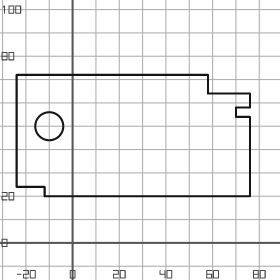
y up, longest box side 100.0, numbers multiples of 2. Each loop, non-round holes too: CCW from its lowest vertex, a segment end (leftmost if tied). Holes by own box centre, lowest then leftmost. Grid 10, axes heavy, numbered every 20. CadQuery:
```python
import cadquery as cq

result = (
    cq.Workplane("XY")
    .moveTo(-12.0, 20.0)
    .lineTo(76.0, 20.0)
    .lineTo(76.0, 54.0)
    .lineTo(70.0, 54.0)
    .lineTo(70.0, 58.0)
    .lineTo(76.0, 58.0)
    .lineTo(76.0, 64.0)
    .lineTo(58.0, 64.0)
    .lineTo(58.0, 72.0)
    .lineTo(-24.0, 72.0)
    .lineTo(-24.0, 24.0)
    .lineTo(-12.0, 24.0)
    .close()
    .moveTo(-10.0, 50.0)
    .circle(6.0)
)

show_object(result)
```